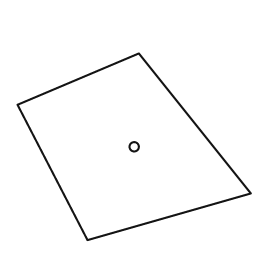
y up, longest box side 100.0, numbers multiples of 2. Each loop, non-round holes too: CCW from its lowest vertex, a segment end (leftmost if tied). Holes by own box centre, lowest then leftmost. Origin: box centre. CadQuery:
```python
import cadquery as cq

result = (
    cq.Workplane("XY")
    .moveTo(-20.0, -40.0)
    .lineTo(50.0, -20.0)
    .lineTo(2.0, 40.0)
    .lineTo(-50.0, 18.0)
    .close()
    .moveTo(0.0, 0.0)
    .circle(2.0)
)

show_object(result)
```